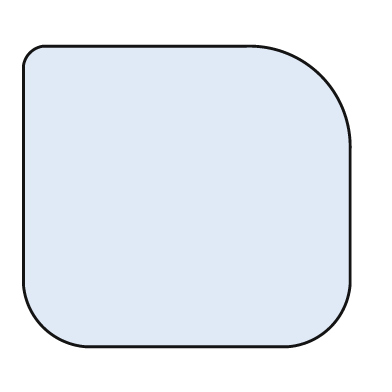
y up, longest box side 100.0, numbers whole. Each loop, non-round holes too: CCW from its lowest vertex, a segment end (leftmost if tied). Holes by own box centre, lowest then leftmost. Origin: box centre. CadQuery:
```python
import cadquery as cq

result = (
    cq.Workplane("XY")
    .moveTo(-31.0, -46.0)
    .lineTo(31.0, -46.0)
    .threePointArc((44.0, -40.0), (50.0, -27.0))
    .lineTo(50.0, 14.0)
    .threePointArc((41.0, 37.0), (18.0, 46.0))
    .lineTo(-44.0, 46.0)
    .threePointArc((-48.0, 44.0), (-50.0, 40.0))
    .lineTo(-50.0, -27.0)
    .threePointArc((-44.0, -40.0), (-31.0, -46.0))
    .close()
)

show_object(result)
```